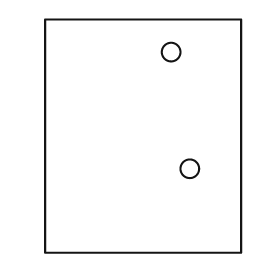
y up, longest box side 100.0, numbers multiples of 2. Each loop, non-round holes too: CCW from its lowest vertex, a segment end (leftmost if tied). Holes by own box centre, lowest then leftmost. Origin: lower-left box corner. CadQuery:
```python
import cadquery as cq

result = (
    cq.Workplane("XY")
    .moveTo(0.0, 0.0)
    .lineTo(84.0, 0.0)
    .lineTo(84.0, 100.0)
    .lineTo(0.0, 100.0)
    .close()
    .moveTo(62.0, 36.0)
    .circle(4.0)
    .moveTo(54.0, 86.0)
    .circle(4.0)
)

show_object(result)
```